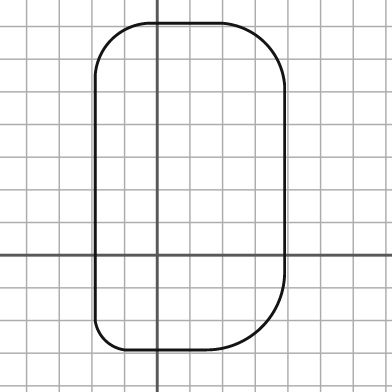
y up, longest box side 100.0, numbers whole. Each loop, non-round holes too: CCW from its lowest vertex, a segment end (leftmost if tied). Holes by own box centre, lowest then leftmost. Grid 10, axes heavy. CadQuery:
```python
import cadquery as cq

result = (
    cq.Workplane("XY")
    .moveTo(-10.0, -29.0)
    .lineTo(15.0, -29.0)
    .threePointArc((32.0, -22.0), (39.0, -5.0))
    .lineTo(39.0, 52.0)
    .threePointArc((33.0, 65.0), (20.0, 71.0))
    .lineTo(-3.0, 71.0)
    .threePointArc((-14.0, 66.0), (-19.0, 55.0))
    .lineTo(-19.0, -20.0)
    .threePointArc((-16.0, -26.0), (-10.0, -29.0))
    .close()
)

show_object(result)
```